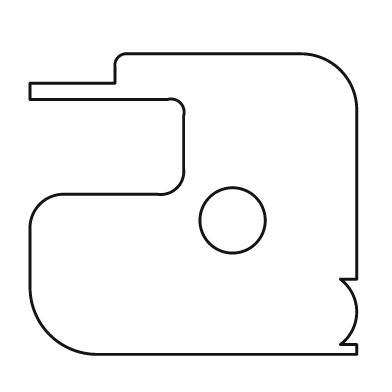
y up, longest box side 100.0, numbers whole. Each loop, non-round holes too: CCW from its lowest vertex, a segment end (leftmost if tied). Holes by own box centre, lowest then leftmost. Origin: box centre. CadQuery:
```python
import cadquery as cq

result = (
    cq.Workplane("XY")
    .moveTo(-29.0, -46.0)
    .lineTo(50.0, -46.0)
    .lineTo(50.0, -43.0)
    .lineTo(45.0, -43.0)
    .threePointArc((50.0, -33.0), (45.0, -23.0))
    .lineTo(50.0, -23.0)
    .lineTo(50.0, 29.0)
    .threePointArc((45.0, 41.0), (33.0, 46.0))
    .lineTo(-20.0, 46.0)
    .threePointArc((-23.0, 45.0), (-24.0, 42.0))
    .lineTo(-24.0, 37.0)
    .lineTo(-50.0, 37.0)
    .lineTo(-50.0, 32.0)
    .lineTo(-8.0, 32.0)
    .threePointArc((-4.0, 31.0), (-3.0, 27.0))
    .lineTo(-3.0, 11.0)
    .threePointArc((-5.0, 5.0), (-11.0, 3.0))
    .lineTo(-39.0, 3.0)
    .threePointArc((-47.0, 0.0), (-50.0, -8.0))
    .lineTo(-50.0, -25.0)
    .threePointArc((-44.0, -40.0), (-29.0, -46.0))
    .close()
    .moveTo(12.0, -5.0)
    .circle(10.0)
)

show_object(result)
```